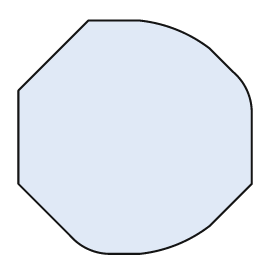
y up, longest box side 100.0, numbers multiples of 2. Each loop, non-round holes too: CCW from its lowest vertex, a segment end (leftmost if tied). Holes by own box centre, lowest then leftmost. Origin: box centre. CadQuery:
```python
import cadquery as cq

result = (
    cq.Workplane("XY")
    .moveTo(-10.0, -50.0)
    .lineTo(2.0, -50.0)
    .threePointArc((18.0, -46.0), (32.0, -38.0))
    .lineTo(50.0, -20.0)
    .lineTo(50.0, 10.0)
    .threePointArc((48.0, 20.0), (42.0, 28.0))
    .lineTo(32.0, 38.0)
    .threePointArc((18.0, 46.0), (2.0, 50.0))
    .lineTo(-20.0, 50.0)
    .lineTo(-50.0, 20.0)
    .lineTo(-50.0, -20.0)
    .lineTo(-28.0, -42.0)
    .threePointArc((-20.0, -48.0), (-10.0, -50.0))
    .close()
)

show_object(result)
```